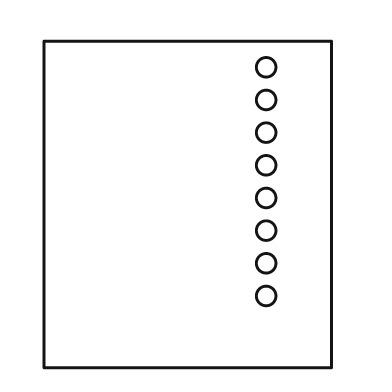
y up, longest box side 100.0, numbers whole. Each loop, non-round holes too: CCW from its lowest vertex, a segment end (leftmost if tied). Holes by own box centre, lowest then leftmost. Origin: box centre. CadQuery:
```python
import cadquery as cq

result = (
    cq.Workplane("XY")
    .moveTo(-44.0, -50.0)
    .lineTo(44.0, -50.0)
    .lineTo(44.0, 50.0)
    .lineTo(-44.0, 50.0)
    .close()
    .moveTo(24.0, -28.0)
    .circle(3.0)
    .moveTo(24.0, -18.0)
    .circle(3.0)
    .moveTo(24.0, -8.0)
    .circle(3.0)
    .moveTo(24.0, 2.0)
    .circle(3.0)
    .moveTo(24.0, 12.0)
    .circle(3.0)
    .moveTo(24.0, 22.0)
    .circle(3.0)
    .moveTo(24.0, 32.0)
    .circle(3.0)
    .moveTo(24.0, 42.0)
    .circle(3.0)
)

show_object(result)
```